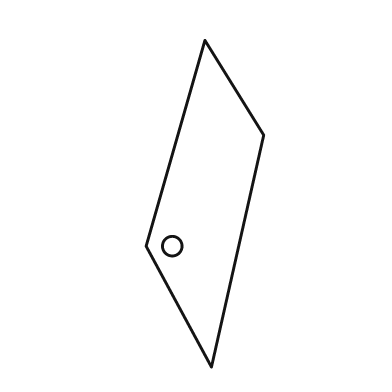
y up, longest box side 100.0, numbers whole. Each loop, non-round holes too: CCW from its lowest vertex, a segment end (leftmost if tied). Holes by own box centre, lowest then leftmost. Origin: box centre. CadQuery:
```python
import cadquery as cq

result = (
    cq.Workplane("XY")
    .moveTo(2.0, -50.0)
    .lineTo(18.0, 21.0)
    .lineTo(0.0, 50.0)
    .lineTo(-18.0, -13.0)
    .close()
    .moveTo(-10.0, -13.0)
    .circle(3.0)
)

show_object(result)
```